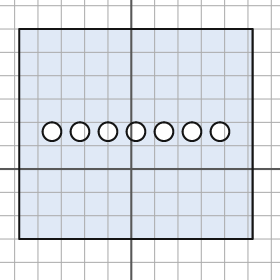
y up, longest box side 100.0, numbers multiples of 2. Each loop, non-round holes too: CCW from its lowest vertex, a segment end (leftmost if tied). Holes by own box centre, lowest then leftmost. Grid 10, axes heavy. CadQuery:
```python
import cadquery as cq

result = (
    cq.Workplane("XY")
    .moveTo(-48.0, -30.0)
    .lineTo(52.0, -30.0)
    .lineTo(52.0, 60.0)
    .lineTo(-48.0, 60.0)
    .close()
    .moveTo(-34.0, 16.0)
    .circle(4.0)
    .moveTo(-22.0, 16.0)
    .circle(4.0)
    .moveTo(-10.0, 16.0)
    .circle(4.0)
    .moveTo(2.0, 16.0)
    .circle(4.0)
    .moveTo(14.0, 16.0)
    .circle(4.0)
    .moveTo(26.0, 16.0)
    .circle(4.0)
    .moveTo(38.0, 16.0)
    .circle(4.0)
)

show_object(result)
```